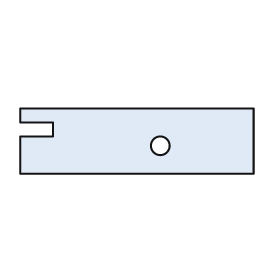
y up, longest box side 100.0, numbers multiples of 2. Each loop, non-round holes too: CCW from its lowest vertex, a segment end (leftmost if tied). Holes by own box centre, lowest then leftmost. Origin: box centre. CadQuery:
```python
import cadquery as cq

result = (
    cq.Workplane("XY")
    .moveTo(-50.0, -14.0)
    .lineTo(50.0, -14.0)
    .lineTo(50.0, 14.0)
    .lineTo(-50.0, 14.0)
    .lineTo(-50.0, 8.0)
    .lineTo(-36.0, 8.0)
    .lineTo(-36.0, 2.0)
    .lineTo(-50.0, 2.0)
    .close()
    .moveTo(10.0, -2.0)
    .circle(4.0)
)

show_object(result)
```